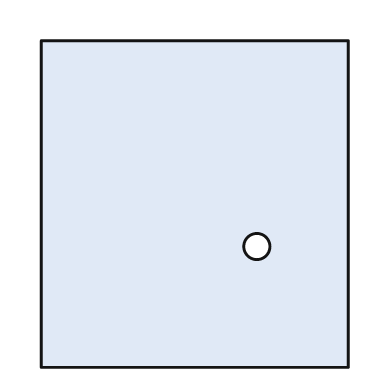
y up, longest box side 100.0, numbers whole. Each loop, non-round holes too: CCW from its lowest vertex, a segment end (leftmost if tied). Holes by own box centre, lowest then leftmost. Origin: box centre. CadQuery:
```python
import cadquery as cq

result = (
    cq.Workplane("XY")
    .moveTo(-47.0, -50.0)
    .lineTo(47.0, -50.0)
    .lineTo(47.0, 50.0)
    .lineTo(-47.0, 50.0)
    .close()
    .moveTo(19.0, -13.0)
    .circle(4.0)
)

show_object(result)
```